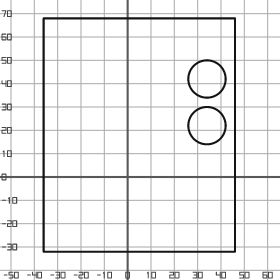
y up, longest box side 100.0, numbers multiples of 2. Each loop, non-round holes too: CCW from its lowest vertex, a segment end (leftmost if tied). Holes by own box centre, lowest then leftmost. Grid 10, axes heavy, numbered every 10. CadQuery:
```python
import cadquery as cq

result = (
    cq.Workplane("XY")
    .moveTo(-36.0, -32.0)
    .lineTo(46.0, -32.0)
    .lineTo(46.0, 68.0)
    .lineTo(-36.0, 68.0)
    .close()
    .moveTo(34.0, 22.0)
    .circle(8.0)
    .moveTo(34.0, 42.0)
    .circle(8.0)
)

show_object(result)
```